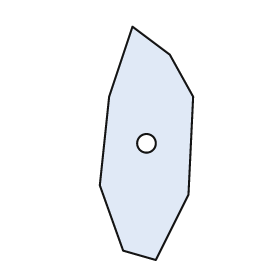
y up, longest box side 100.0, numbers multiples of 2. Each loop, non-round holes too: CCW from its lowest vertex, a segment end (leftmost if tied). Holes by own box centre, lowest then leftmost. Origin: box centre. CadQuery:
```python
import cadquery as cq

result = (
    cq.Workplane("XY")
    .moveTo(4.0, -50.0)
    .lineTo(18.0, -22.0)
    .lineTo(20.0, 20.0)
    .lineTo(10.0, 38.0)
    .lineTo(-6.0, 50.0)
    .lineTo(-16.0, 20.0)
    .lineTo(-20.0, -18.0)
    .lineTo(-10.0, -46.0)
    .close()
    .moveTo(0.0, 0.0)
    .circle(4.0)
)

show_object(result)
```